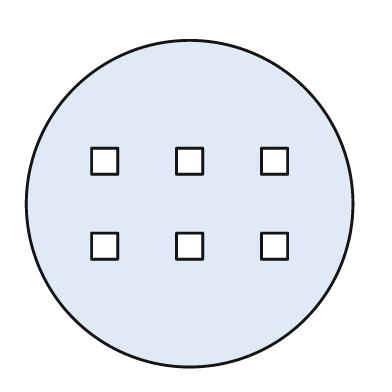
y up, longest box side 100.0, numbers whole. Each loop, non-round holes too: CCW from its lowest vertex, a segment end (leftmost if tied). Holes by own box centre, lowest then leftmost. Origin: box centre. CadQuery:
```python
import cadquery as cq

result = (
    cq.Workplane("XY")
    .moveTo(0.0, 0.0)
    .circle(50.0)
    .moveTo(-30.0, -17.0)
    .lineTo(-22.0, -17.0)
    .lineTo(-22.0, -9.0)
    .lineTo(-30.0, -9.0)
    .close()
    .moveTo(-4.0, -17.0)
    .lineTo(4.0, -17.0)
    .lineTo(4.0, -9.0)
    .lineTo(-4.0, -9.0)
    .close()
    .moveTo(22.0, -17.0)
    .lineTo(30.0, -17.0)
    .lineTo(30.0, -9.0)
    .lineTo(22.0, -9.0)
    .close()
    .moveTo(-30.0, 9.0)
    .lineTo(-22.0, 9.0)
    .lineTo(-22.0, 17.0)
    .lineTo(-30.0, 17.0)
    .close()
    .moveTo(-4.0, 9.0)
    .lineTo(4.0, 9.0)
    .lineTo(4.0, 17.0)
    .lineTo(-4.0, 17.0)
    .close()
    .moveTo(22.0, 9.0)
    .lineTo(30.0, 9.0)
    .lineTo(30.0, 17.0)
    .lineTo(22.0, 17.0)
    .close()
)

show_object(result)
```